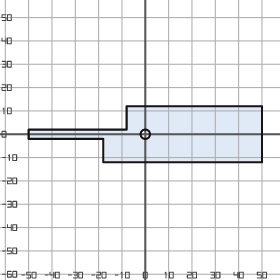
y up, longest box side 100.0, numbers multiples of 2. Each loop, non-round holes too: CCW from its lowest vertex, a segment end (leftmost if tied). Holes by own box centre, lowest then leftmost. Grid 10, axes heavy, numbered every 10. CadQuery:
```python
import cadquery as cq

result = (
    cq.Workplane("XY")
    .moveTo(-18.0, -12.0)
    .lineTo(50.0, -12.0)
    .lineTo(50.0, 12.0)
    .lineTo(-8.0, 12.0)
    .lineTo(-8.0, 2.0)
    .lineTo(-50.0, 2.0)
    .lineTo(-50.0, -2.0)
    .lineTo(-18.0, -2.0)
    .close()
    .moveTo(0.0, 0.0)
    .circle(2.0)
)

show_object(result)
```